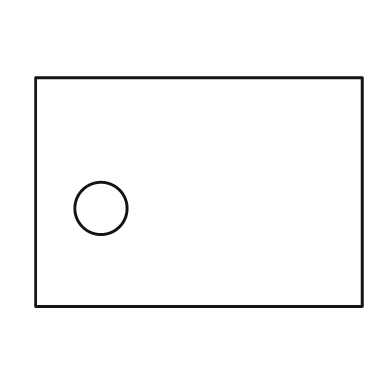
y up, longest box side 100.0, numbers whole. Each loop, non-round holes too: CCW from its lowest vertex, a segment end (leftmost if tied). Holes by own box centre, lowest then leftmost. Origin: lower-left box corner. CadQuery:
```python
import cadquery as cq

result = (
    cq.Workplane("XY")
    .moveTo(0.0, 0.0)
    .lineTo(100.0, 0.0)
    .lineTo(100.0, 70.0)
    .lineTo(0.0, 70.0)
    .close()
    .moveTo(20.0, 30.0)
    .circle(8.0)
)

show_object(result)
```